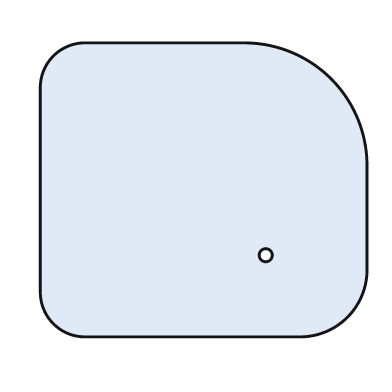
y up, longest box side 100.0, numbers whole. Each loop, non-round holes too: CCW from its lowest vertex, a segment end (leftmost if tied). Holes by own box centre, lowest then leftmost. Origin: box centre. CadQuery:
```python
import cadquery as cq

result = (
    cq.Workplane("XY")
    .moveTo(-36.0, -45.0)
    .lineTo(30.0, -45.0)
    .threePointArc((44.0, -39.0), (50.0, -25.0))
    .lineTo(50.0, 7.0)
    .threePointArc((39.0, 34.0), (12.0, 45.0))
    .lineTo(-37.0, 45.0)
    .threePointArc((-46.0, 41.0), (-50.0, 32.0))
    .lineTo(-50.0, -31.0)
    .threePointArc((-46.0, -41.0), (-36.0, -45.0))
    .close()
    .moveTo(19.0, -20.0)
    .circle(2.0)
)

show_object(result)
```